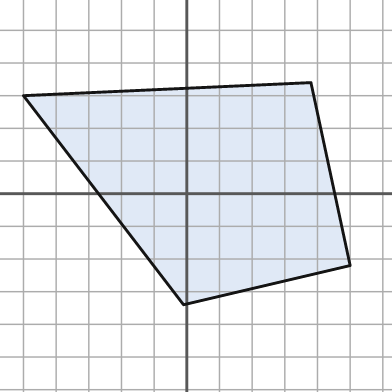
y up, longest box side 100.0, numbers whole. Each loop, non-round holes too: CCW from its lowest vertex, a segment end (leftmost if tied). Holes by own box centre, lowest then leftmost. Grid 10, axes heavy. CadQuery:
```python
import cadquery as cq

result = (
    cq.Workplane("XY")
    .moveTo(-1.0, -34.0)
    .lineTo(50.0, -22.0)
    .lineTo(38.0, 34.0)
    .lineTo(-50.0, 30.0)
    .close()
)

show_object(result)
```